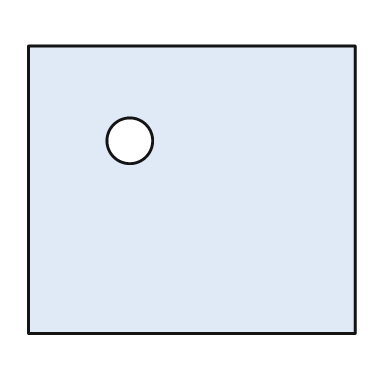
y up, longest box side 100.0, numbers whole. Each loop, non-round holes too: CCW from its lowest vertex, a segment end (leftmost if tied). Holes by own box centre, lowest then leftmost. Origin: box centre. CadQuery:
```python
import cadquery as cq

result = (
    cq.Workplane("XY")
    .moveTo(-50.0, -44.0)
    .lineTo(50.0, -44.0)
    .lineTo(50.0, 44.0)
    .lineTo(-50.0, 44.0)
    .close()
    .moveTo(-19.0, 15.0)
    .circle(7.0)
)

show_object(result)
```